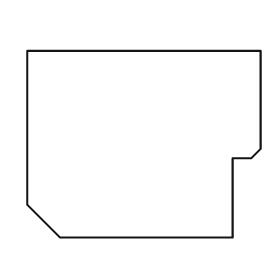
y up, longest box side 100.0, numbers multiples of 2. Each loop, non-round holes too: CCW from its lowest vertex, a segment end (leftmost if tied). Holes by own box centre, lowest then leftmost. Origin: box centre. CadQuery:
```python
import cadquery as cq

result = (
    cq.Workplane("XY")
    .moveTo(-36.0, -40.0)
    .lineTo(38.0, -40.0)
    .lineTo(38.0, -6.0)
    .lineTo(46.0, -6.0)
    .lineTo(50.0, -2.0)
    .lineTo(50.0, 40.0)
    .lineTo(-50.0, 40.0)
    .lineTo(-50.0, -26.0)
    .close()
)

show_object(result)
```